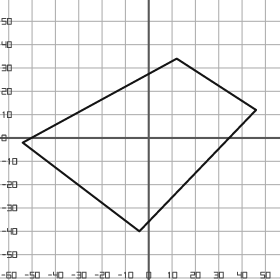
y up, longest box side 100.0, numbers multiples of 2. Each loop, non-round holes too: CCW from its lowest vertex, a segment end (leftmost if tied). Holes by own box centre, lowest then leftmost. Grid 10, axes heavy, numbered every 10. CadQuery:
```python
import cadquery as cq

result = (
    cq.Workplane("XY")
    .moveTo(-4.0, -40.0)
    .lineTo(46.0, 12.0)
    .lineTo(12.0, 34.0)
    .lineTo(-54.0, -2.0)
    .close()
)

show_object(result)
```